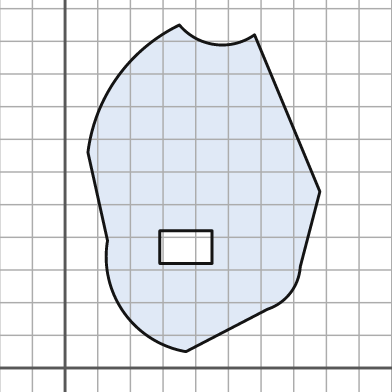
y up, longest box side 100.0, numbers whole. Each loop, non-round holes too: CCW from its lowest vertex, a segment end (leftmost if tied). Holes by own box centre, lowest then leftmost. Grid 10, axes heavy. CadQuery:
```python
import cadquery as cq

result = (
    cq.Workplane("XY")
    .moveTo(37.0, 5.0)
    .lineTo(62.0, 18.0)
    .threePointArc((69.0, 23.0), (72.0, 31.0))
    .lineTo(78.0, 54.0)
    .lineTo(58.0, 102.0)
    .threePointArc((46.0, 99.0), (35.0, 105.0))
    .threePointArc((16.0, 89.0), (7.0, 66.0))
    .lineTo(13.0, 39.0)
    .threePointArc((18.0, 17.0), (37.0, 5.0))
    .close()
    .moveTo(29.0, 32.0)
    .lineTo(45.0, 32.0)
    .lineTo(45.0, 42.0)
    .lineTo(29.0, 42.0)
    .close()
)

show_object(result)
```